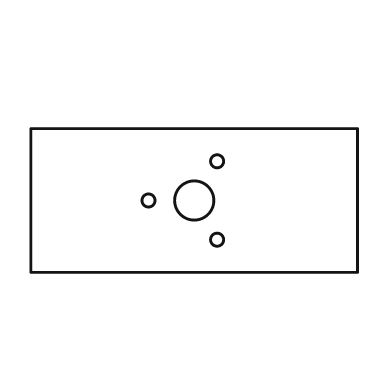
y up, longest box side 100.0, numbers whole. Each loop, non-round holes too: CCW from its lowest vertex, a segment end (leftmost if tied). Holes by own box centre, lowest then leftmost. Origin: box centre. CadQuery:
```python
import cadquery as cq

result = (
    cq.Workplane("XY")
    .moveTo(-50.0, -22.0)
    .lineTo(50.0, -22.0)
    .lineTo(50.0, 22.0)
    .lineTo(-50.0, 22.0)
    .close()
    .moveTo(7.0, -12.0)
    .circle(2.0)
    .moveTo(-14.0, 0.0)
    .circle(2.0)
    .moveTo(0.0, 0.0)
    .circle(6.0)
    .moveTo(7.0, 12.0)
    .circle(2.0)
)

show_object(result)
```